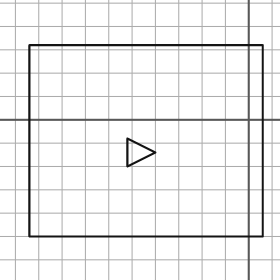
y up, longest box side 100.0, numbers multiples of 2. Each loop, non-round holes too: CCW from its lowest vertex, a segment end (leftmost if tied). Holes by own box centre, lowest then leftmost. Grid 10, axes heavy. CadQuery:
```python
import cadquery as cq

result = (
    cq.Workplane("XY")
    .moveTo(-94.0, -50.0)
    .lineTo(6.0, -50.0)
    .lineTo(6.0, 32.0)
    .lineTo(-94.0, 32.0)
    .close()
    .moveTo(-52.0, -20.0)
    .lineTo(-40.0, -14.0)
    .lineTo(-52.0, -8.0)
    .close()
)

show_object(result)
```